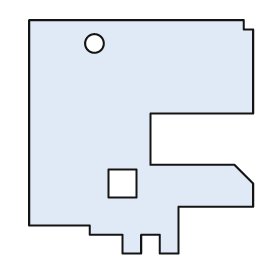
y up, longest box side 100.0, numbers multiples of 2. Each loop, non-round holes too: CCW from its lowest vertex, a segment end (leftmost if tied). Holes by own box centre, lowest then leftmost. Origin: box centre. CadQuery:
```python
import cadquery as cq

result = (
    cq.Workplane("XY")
    .moveTo(-8.0, -50.0)
    .lineTo(0.0, -50.0)
    .lineTo(0.0, -42.0)
    .lineTo(8.0, -42.0)
    .lineTo(8.0, -50.0)
    .lineTo(16.0, -50.0)
    .lineTo(16.0, -30.0)
    .lineTo(48.0, -30.0)
    .lineTo(48.0, -20.0)
    .lineTo(40.0, -12.0)
    .lineTo(4.0, -12.0)
    .lineTo(4.0, 10.0)
    .lineTo(48.0, 10.0)
    .lineTo(48.0, 46.0)
    .lineTo(44.0, 46.0)
    .lineTo(44.0, 50.0)
    .lineTo(-48.0, 50.0)
    .lineTo(-48.0, -38.0)
    .lineTo(-22.0, -38.0)
    .lineTo(-22.0, -42.0)
    .lineTo(-8.0, -42.0)
    .close()
    .moveTo(-14.0, -26.0)
    .lineTo(-2.0, -26.0)
    .lineTo(-2.0, -14.0)
    .lineTo(-14.0, -14.0)
    .close()
    .moveTo(-20.0, 40.0)
    .circle(4.0)
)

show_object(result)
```